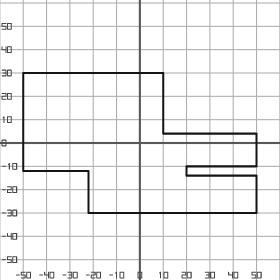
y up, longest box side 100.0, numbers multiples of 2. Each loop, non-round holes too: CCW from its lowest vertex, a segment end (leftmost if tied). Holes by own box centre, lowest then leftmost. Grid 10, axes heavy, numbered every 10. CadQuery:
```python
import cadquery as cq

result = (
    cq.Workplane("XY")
    .moveTo(-22.0, -30.0)
    .lineTo(50.0, -30.0)
    .lineTo(50.0, -14.0)
    .lineTo(20.0, -14.0)
    .lineTo(20.0, -10.0)
    .lineTo(50.0, -10.0)
    .lineTo(50.0, 4.0)
    .lineTo(10.0, 4.0)
    .lineTo(10.0, 30.0)
    .lineTo(-50.0, 30.0)
    .lineTo(-50.0, -12.0)
    .lineTo(-22.0, -12.0)
    .close()
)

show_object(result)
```